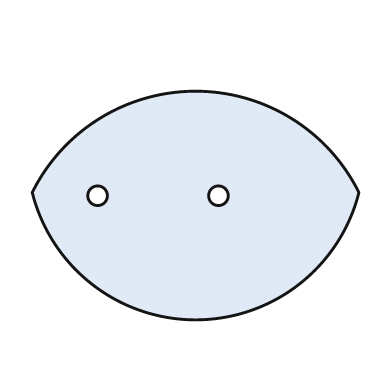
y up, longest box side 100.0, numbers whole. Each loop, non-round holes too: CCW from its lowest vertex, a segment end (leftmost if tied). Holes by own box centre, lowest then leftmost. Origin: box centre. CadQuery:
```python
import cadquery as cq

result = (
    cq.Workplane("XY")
    .moveTo(-50.0, 4.0)
    .threePointArc((0.0, -35.0), (50.0, 4.0))
    .threePointArc((0.0, 35.0), (-50.0, 4.0))
    .close()
    .moveTo(-30.0, 3.0)
    .circle(3.0)
    .moveTo(7.0, 3.0)
    .circle(3.0)
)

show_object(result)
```